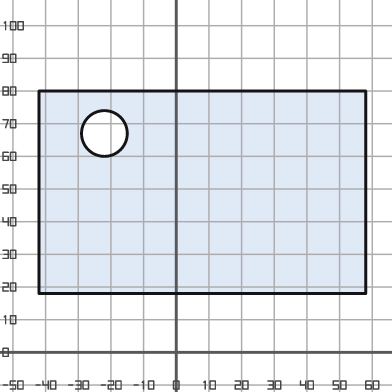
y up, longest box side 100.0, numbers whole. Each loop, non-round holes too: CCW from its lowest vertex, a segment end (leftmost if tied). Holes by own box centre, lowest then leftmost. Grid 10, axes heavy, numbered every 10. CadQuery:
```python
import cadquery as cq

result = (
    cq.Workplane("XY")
    .moveTo(-42.0, 18.0)
    .lineTo(58.0, 18.0)
    .lineTo(58.0, 80.0)
    .lineTo(-42.0, 80.0)
    .close()
    .moveTo(-22.0, 67.0)
    .circle(7.0)
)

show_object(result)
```